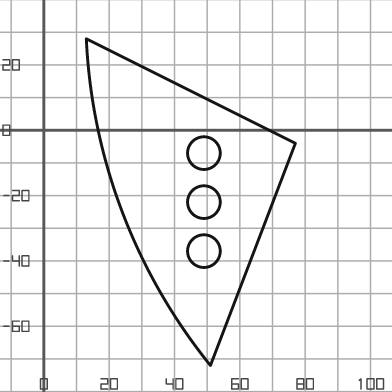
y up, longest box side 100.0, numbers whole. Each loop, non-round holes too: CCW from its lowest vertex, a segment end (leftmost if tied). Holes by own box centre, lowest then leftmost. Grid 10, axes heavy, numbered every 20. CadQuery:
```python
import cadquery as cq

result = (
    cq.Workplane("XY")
    .moveTo(51.0, -72.0)
    .lineTo(77.0, -4.0)
    .lineTo(13.0, 28.0)
    .threePointArc((24.0, -25.0), (51.0, -72.0))
    .close()
    .moveTo(49.0, -37.0)
    .circle(5.0)
    .moveTo(49.0, -22.0)
    .circle(5.0)
    .moveTo(49.0, -7.0)
    .circle(5.0)
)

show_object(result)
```